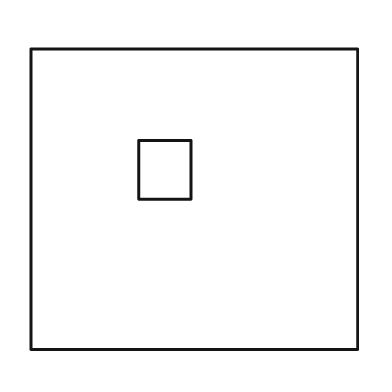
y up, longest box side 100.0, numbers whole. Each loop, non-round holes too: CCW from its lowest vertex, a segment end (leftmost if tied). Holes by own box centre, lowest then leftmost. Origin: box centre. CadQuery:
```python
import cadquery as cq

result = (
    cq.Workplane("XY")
    .moveTo(-50.0, -46.0)
    .lineTo(50.0, -46.0)
    .lineTo(50.0, 46.0)
    .lineTo(-50.0, 46.0)
    .close()
    .moveTo(-17.0, 0.0)
    .lineTo(-1.0, 0.0)
    .lineTo(-1.0, 18.0)
    .lineTo(-17.0, 18.0)
    .close()
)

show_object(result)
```